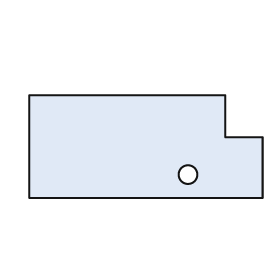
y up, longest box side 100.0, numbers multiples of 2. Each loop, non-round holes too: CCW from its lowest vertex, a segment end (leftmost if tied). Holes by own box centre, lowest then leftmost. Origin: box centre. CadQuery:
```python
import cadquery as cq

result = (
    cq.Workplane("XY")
    .moveTo(-50.0, -22.0)
    .lineTo(50.0, -22.0)
    .lineTo(50.0, 4.0)
    .lineTo(34.0, 4.0)
    .lineTo(34.0, 22.0)
    .lineTo(-50.0, 22.0)
    .close()
    .moveTo(18.0, -12.0)
    .circle(4.0)
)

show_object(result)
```